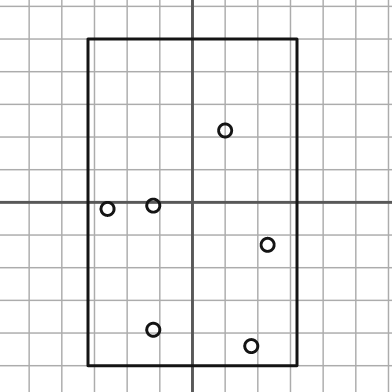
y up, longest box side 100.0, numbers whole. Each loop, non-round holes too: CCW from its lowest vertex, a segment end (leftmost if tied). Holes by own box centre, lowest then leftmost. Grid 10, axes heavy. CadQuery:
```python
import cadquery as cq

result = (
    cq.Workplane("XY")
    .moveTo(-32.0, -50.0)
    .lineTo(32.0, -50.0)
    .lineTo(32.0, 50.0)
    .lineTo(-32.0, 50.0)
    .close()
    .moveTo(18.0, -44.0)
    .circle(2.0)
    .moveTo(-12.0, -39.0)
    .circle(2.0)
    .moveTo(23.0, -13.0)
    .circle(2.0)
    .moveTo(-26.0, -2.0)
    .circle(2.0)
    .moveTo(-12.0, -1.0)
    .circle(2.0)
    .moveTo(10.0, 22.0)
    .circle(2.0)
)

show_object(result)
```